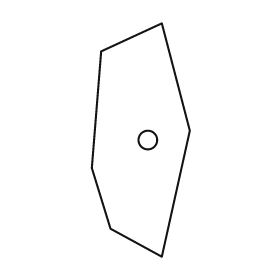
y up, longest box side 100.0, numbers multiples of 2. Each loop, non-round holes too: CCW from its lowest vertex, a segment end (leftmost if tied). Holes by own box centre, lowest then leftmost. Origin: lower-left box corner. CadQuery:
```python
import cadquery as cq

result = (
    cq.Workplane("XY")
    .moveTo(30.0, 0.0)
    .lineTo(42.0, 54.0)
    .lineTo(30.0, 100.0)
    .lineTo(4.0, 88.0)
    .lineTo(0.0, 38.0)
    .lineTo(8.0, 12.0)
    .close()
    .moveTo(24.0, 50.0)
    .circle(4.0)
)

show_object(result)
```